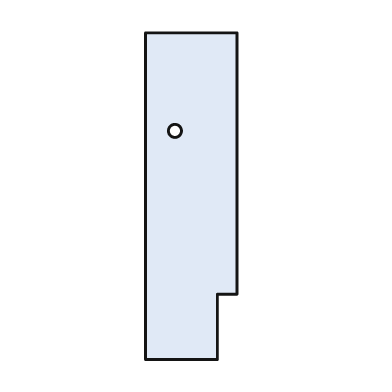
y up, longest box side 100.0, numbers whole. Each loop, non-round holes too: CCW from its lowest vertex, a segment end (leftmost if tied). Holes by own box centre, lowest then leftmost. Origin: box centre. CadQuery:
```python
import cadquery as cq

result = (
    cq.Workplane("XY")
    .moveTo(-14.0, -50.0)
    .lineTo(8.0, -50.0)
    .lineTo(8.0, -30.0)
    .lineTo(14.0, -30.0)
    .lineTo(14.0, 50.0)
    .lineTo(-14.0, 50.0)
    .close()
    .moveTo(-5.0, 20.0)
    .circle(2.0)
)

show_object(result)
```